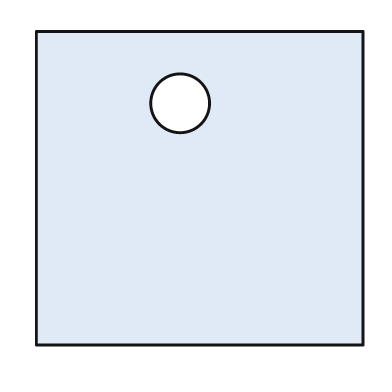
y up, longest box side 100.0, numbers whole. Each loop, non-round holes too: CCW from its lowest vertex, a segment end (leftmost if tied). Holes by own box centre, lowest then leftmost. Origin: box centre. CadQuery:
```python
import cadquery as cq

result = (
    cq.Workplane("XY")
    .moveTo(-50.0, -48.0)
    .lineTo(50.0, -48.0)
    .lineTo(50.0, 48.0)
    .lineTo(-50.0, 48.0)
    .close()
    .moveTo(-6.0, 26.0)
    .circle(9.0)
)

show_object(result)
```